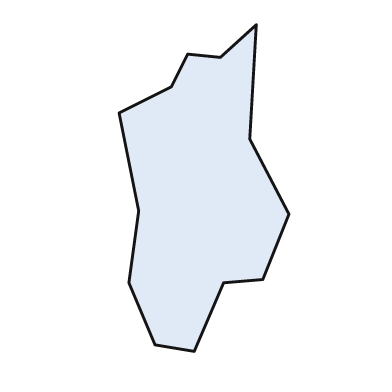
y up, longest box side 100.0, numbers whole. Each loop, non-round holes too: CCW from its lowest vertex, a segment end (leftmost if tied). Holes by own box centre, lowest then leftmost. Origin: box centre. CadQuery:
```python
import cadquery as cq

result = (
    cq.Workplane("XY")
    .moveTo(-3.0, -50.0)
    .lineTo(6.0, -29.0)
    .lineTo(18.0, -28.0)
    .lineTo(26.0, -8.0)
    .lineTo(14.0, 15.0)
    .lineTo(16.0, 50.0)
    .lineTo(5.0, 40.0)
    .lineTo(-5.0, 41.0)
    .lineTo(-10.0, 31.0)
    .lineTo(-26.0, 23.0)
    .lineTo(-20.0, -7.0)
    .lineTo(-23.0, -29.0)
    .lineTo(-15.0, -48.0)
    .close()
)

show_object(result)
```